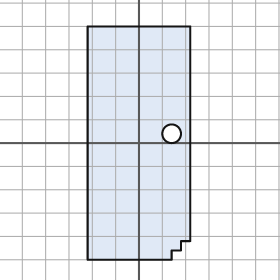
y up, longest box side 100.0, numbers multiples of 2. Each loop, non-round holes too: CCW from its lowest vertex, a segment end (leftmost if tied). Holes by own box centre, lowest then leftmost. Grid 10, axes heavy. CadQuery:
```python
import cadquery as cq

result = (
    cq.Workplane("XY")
    .moveTo(-22.0, -50.0)
    .lineTo(14.0, -50.0)
    .lineTo(14.0, -46.0)
    .lineTo(18.0, -46.0)
    .lineTo(18.0, -42.0)
    .lineTo(22.0, -42.0)
    .lineTo(22.0, 50.0)
    .lineTo(-22.0, 50.0)
    .close()
    .moveTo(14.0, 4.0)
    .circle(4.0)
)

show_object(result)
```